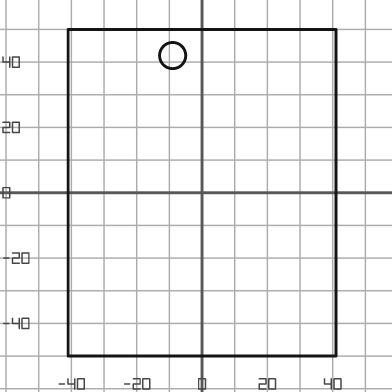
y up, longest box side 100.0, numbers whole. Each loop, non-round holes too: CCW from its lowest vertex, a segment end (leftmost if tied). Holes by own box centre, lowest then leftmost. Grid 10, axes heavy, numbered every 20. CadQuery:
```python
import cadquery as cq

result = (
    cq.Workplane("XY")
    .moveTo(-41.0, -50.0)
    .lineTo(41.0, -50.0)
    .lineTo(41.0, 50.0)
    .lineTo(-41.0, 50.0)
    .close()
    .moveTo(-9.0, 42.0)
    .circle(4.0)
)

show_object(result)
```